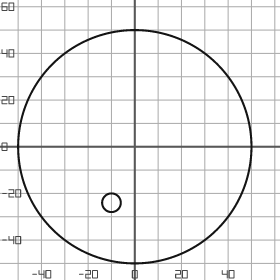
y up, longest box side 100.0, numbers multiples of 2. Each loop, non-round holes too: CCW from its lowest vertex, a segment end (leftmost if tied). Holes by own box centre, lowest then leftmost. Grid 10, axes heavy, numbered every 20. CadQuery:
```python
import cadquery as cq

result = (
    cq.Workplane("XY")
    .moveTo(0.0, 0.0)
    .circle(50.0)
    .moveTo(-10.0, -24.0)
    .circle(4.0)
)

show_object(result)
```